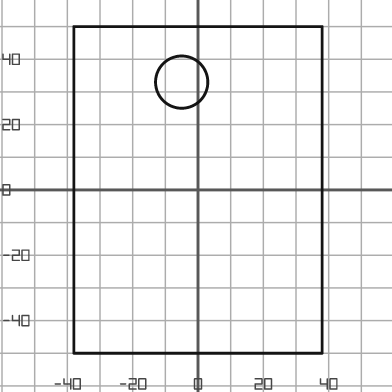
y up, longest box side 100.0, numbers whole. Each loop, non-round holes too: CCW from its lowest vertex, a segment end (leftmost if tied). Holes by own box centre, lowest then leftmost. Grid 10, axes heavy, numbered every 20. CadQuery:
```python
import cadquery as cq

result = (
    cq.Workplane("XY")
    .moveTo(-38.0, -50.0)
    .lineTo(38.0, -50.0)
    .lineTo(38.0, 50.0)
    .lineTo(-38.0, 50.0)
    .close()
    .moveTo(-5.0, 33.0)
    .circle(8.0)
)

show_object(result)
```